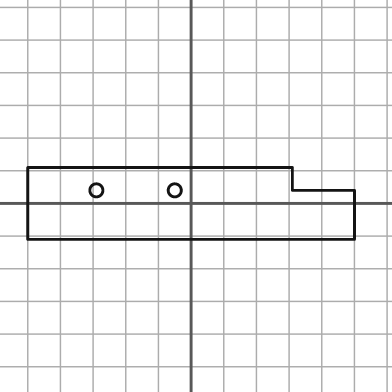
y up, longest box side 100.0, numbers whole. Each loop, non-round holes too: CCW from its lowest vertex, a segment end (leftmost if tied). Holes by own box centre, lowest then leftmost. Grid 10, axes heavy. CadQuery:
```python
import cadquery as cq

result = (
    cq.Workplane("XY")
    .moveTo(-50.0, -11.0)
    .lineTo(50.0, -11.0)
    .lineTo(50.0, 4.0)
    .lineTo(31.0, 4.0)
    .lineTo(31.0, 11.0)
    .lineTo(-50.0, 11.0)
    .close()
    .moveTo(-29.0, 4.0)
    .circle(2.0)
    .moveTo(-5.0, 4.0)
    .circle(2.0)
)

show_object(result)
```